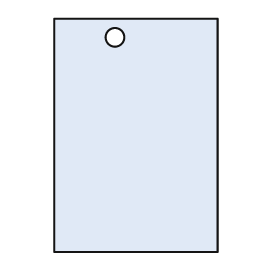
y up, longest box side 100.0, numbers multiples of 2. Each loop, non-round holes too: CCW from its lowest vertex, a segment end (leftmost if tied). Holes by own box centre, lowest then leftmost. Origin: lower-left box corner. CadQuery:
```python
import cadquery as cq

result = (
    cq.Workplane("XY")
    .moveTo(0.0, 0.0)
    .lineTo(70.0, 0.0)
    .lineTo(70.0, 100.0)
    .lineTo(0.0, 100.0)
    .close()
    .moveTo(26.0, 92.0)
    .circle(4.0)
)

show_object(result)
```